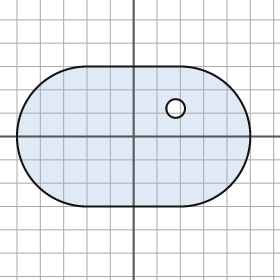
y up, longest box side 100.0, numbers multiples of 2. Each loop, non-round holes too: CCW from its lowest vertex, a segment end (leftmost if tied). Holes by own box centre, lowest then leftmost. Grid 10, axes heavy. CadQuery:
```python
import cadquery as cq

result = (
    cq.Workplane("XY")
    .moveTo(-20.0, -30.0)
    .lineTo(20.0, -30.0)
    .threePointArc((50.0, 0.0), (20.0, 30.0))
    .lineTo(-20.0, 30.0)
    .threePointArc((-50.0, 0.0), (-20.0, -30.0))
    .close()
    .moveTo(18.0, 12.0)
    .circle(4.0)
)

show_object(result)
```